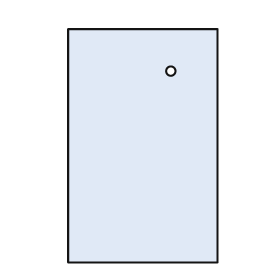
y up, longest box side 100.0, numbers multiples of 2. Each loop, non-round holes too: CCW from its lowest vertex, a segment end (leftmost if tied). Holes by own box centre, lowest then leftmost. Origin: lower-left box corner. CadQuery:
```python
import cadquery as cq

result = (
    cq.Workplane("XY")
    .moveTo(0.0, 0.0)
    .lineTo(64.0, 0.0)
    .lineTo(64.0, 100.0)
    .lineTo(0.0, 100.0)
    .close()
    .moveTo(44.0, 82.0)
    .circle(2.0)
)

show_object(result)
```